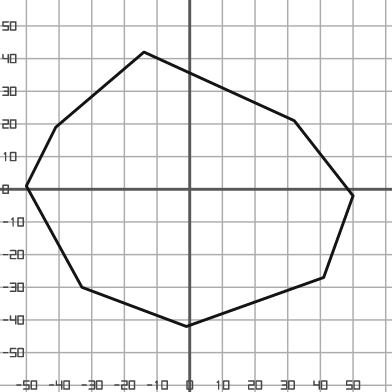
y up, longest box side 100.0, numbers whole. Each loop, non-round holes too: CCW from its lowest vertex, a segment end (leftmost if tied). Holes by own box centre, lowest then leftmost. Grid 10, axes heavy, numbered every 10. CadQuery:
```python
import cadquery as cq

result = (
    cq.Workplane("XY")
    .moveTo(-1.0, -42.0)
    .lineTo(41.0, -27.0)
    .lineTo(50.0, -2.0)
    .lineTo(32.0, 21.0)
    .lineTo(-14.0, 42.0)
    .lineTo(-41.0, 19.0)
    .lineTo(-50.0, 1.0)
    .lineTo(-33.0, -30.0)
    .close()
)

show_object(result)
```